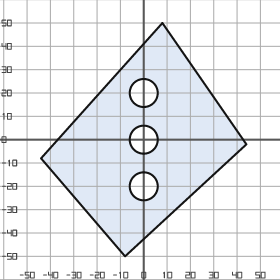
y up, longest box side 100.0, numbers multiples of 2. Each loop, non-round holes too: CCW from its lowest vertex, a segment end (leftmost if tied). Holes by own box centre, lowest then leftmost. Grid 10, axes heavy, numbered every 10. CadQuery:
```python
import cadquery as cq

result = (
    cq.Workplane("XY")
    .moveTo(-8.0, -50.0)
    .lineTo(44.0, -2.0)
    .lineTo(8.0, 50.0)
    .lineTo(-44.0, -8.0)
    .close()
    .moveTo(0.0, -20.0)
    .circle(6.0)
    .moveTo(0.0, 0.0)
    .circle(6.0)
    .moveTo(0.0, 20.0)
    .circle(6.0)
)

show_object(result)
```